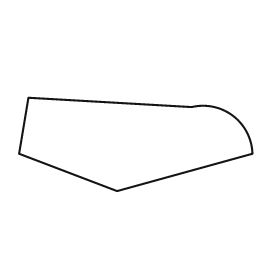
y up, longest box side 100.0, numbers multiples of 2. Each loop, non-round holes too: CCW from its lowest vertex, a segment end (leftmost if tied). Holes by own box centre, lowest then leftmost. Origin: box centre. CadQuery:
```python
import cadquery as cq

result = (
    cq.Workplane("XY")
    .moveTo(-8.0, -20.0)
    .lineTo(50.0, -4.0)
    .threePointArc((42.0, 12.0), (24.0, 16.0))
    .lineTo(-46.0, 20.0)
    .lineTo(-50.0, -4.0)
    .close()
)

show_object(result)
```